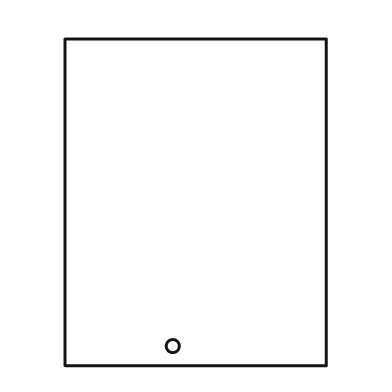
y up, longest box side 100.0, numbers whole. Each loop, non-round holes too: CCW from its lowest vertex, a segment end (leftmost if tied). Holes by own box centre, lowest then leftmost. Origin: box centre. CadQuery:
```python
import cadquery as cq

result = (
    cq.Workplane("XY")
    .moveTo(-40.0, -50.0)
    .lineTo(40.0, -50.0)
    .lineTo(40.0, 50.0)
    .lineTo(-40.0, 50.0)
    .close()
    .moveTo(-7.0, -44.0)
    .circle(2.0)
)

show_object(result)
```